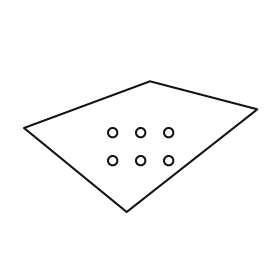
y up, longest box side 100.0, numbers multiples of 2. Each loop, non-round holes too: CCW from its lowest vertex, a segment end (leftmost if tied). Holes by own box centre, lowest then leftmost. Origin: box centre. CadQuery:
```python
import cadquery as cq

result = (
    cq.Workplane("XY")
    .moveTo(-6.0, -28.0)
    .lineTo(50.0, 16.0)
    .lineTo(4.0, 28.0)
    .lineTo(-50.0, 8.0)
    .close()
    .moveTo(-12.0, -6.0)
    .circle(2.0)
    .moveTo(0.0, -6.0)
    .circle(2.0)
    .moveTo(12.0, -6.0)
    .circle(2.0)
    .moveTo(-12.0, 6.0)
    .circle(2.0)
    .moveTo(0.0, 6.0)
    .circle(2.0)
    .moveTo(12.0, 6.0)
    .circle(2.0)
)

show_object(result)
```